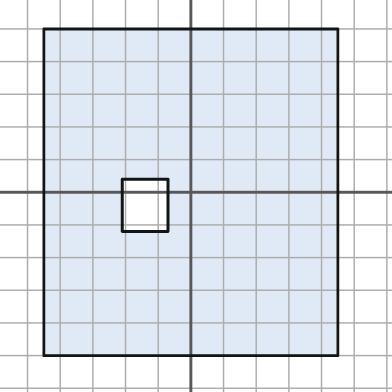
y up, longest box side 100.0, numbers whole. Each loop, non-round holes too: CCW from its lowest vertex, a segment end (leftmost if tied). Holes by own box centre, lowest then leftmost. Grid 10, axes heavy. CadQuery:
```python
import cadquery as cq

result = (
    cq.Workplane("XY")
    .moveTo(-45.0, -50.0)
    .lineTo(45.0, -50.0)
    .lineTo(45.0, 50.0)
    .lineTo(-45.0, 50.0)
    .close()
    .moveTo(-21.0, -12.0)
    .lineTo(-7.0, -12.0)
    .lineTo(-7.0, 4.0)
    .lineTo(-21.0, 4.0)
    .close()
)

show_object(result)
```